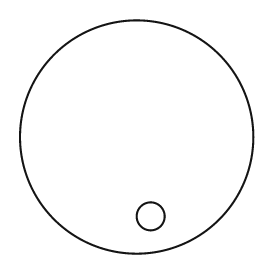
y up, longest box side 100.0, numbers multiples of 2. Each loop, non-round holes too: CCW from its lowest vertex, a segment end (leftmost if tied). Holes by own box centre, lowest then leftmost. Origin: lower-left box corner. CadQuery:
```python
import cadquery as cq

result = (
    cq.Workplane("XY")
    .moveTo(50.0, 50.0)
    .circle(50.0)
    .moveTo(56.0, 16.0)
    .circle(6.0)
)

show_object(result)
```